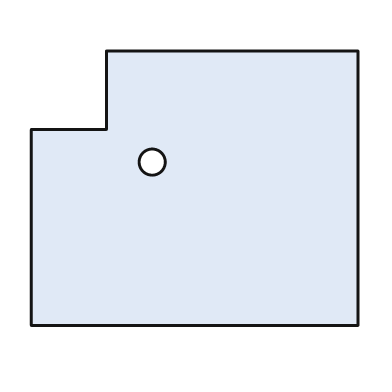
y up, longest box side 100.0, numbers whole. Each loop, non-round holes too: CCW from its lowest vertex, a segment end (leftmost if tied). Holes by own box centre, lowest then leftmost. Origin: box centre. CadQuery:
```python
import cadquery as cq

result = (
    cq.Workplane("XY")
    .moveTo(-50.0, -42.0)
    .lineTo(50.0, -42.0)
    .lineTo(50.0, 42.0)
    .lineTo(-27.0, 42.0)
    .lineTo(-27.0, 18.0)
    .lineTo(-50.0, 18.0)
    .close()
    .moveTo(-13.0, 8.0)
    .circle(4.0)
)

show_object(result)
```